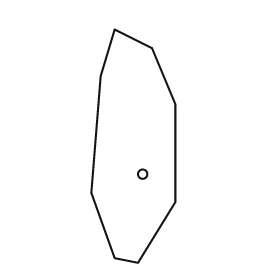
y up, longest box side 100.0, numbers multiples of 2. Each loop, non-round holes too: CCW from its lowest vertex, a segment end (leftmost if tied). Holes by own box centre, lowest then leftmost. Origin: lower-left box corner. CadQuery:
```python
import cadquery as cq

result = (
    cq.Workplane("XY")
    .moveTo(20.0, 0.0)
    .lineTo(36.0, 26.0)
    .lineTo(36.0, 68.0)
    .lineTo(26.0, 92.0)
    .lineTo(10.0, 100.0)
    .lineTo(4.0, 80.0)
    .lineTo(0.0, 30.0)
    .lineTo(10.0, 2.0)
    .close()
    .moveTo(22.0, 38.0)
    .circle(2.0)
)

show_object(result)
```